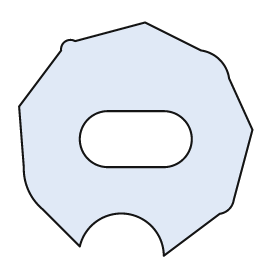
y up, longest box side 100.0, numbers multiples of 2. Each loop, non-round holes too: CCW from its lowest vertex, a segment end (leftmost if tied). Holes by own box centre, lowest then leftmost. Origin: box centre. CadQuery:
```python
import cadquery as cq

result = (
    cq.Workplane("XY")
    .moveTo(12.0, -50.0)
    .lineTo(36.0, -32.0)
    .threePointArc((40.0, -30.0), (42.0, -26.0))
    .lineTo(50.0, 4.0)
    .lineTo(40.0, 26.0)
    .threePointArc((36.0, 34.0), (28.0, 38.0))
    .lineTo(4.0, 50.0)
    .lineTo(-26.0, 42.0)
    .threePointArc((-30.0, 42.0), (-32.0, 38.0))
    .lineTo(-50.0, 14.0)
    .lineTo(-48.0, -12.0)
    .threePointArc((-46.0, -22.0), (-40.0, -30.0))
    .lineTo(-24.0, -46.0)
    .threePointArc((-4.0, -32.0), (12.0, -50.0))
    .close()
    .moveTo(-12.0, -12.0)
    .lineTo(12.0, -12.0)
    .threePointArc((24.0, 0.0), (12.0, 12.0))
    .lineTo(-12.0, 12.0)
    .threePointArc((-24.0, 0.0), (-12.0, -12.0))
    .close()
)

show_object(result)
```